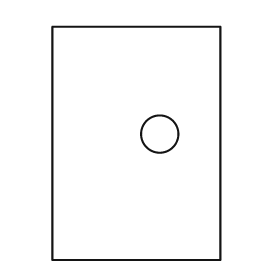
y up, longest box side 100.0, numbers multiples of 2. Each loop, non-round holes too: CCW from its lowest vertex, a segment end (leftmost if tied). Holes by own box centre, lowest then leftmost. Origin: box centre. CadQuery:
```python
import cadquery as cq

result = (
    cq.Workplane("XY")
    .moveTo(-36.0, -50.0)
    .lineTo(36.0, -50.0)
    .lineTo(36.0, 50.0)
    .lineTo(-36.0, 50.0)
    .close()
    .moveTo(10.0, 4.0)
    .circle(8.0)
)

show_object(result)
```